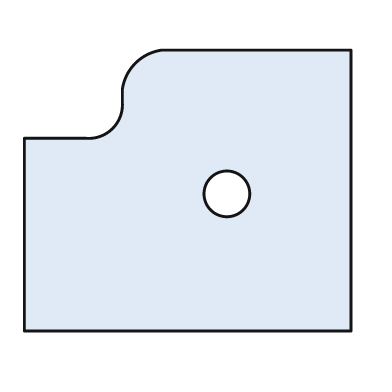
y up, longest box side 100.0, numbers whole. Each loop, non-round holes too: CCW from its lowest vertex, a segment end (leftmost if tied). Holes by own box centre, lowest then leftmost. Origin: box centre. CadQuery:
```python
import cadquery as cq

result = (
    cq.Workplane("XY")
    .moveTo(-50.0, -43.0)
    .lineTo(50.0, -43.0)
    .lineTo(50.0, 43.0)
    .lineTo(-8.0, 43.0)
    .threePointArc((-16.0, 39.0), (-20.0, 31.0))
    .lineTo(-20.0, 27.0)
    .threePointArc((-23.0, 19.0), (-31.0, 16.0))
    .lineTo(-50.0, 16.0)
    .close()
    .moveTo(12.0, -1.0)
    .circle(7.0)
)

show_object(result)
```